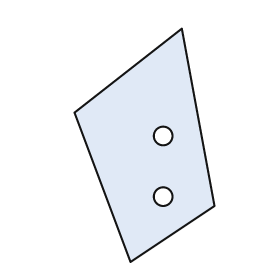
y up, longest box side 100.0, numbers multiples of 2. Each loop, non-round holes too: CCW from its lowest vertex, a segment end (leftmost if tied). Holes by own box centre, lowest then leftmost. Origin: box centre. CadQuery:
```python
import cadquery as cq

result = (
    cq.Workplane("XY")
    .moveTo(-6.0, -50.0)
    .lineTo(30.0, -26.0)
    .lineTo(16.0, 50.0)
    .lineTo(-30.0, 14.0)
    .close()
    .moveTo(8.0, -22.0)
    .circle(4.0)
    .moveTo(8.0, 4.0)
    .circle(4.0)
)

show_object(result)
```